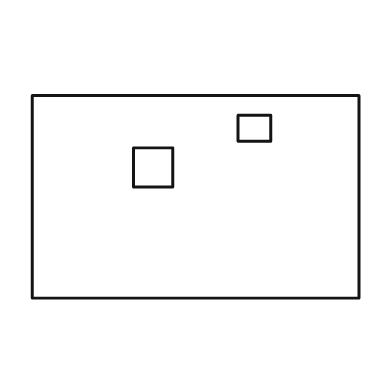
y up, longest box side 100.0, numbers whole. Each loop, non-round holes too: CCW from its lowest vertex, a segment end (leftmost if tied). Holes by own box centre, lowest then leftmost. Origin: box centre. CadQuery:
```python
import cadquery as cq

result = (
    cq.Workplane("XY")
    .moveTo(-50.0, -31.0)
    .lineTo(50.0, -31.0)
    .lineTo(50.0, 31.0)
    .lineTo(-50.0, 31.0)
    .close()
    .moveTo(-19.0, 3.0)
    .lineTo(-7.0, 3.0)
    .lineTo(-7.0, 15.0)
    .lineTo(-19.0, 15.0)
    .close()
    .moveTo(13.0, 17.0)
    .lineTo(23.0, 17.0)
    .lineTo(23.0, 25.0)
    .lineTo(13.0, 25.0)
    .close()
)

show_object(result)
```